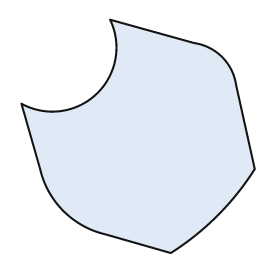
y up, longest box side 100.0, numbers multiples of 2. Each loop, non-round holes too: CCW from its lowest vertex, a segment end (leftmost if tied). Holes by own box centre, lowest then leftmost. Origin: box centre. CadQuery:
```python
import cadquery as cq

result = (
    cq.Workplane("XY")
    .moveTo(14.0, -50.0)
    .threePointArc((34.0, -34.0), (50.0, -14.0))
    .lineTo(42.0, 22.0)
    .threePointArc((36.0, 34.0), (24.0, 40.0))
    .lineTo(-12.0, 50.0)
    .threePointArc((-18.0, 18.0), (-50.0, 14.0))
    .lineTo(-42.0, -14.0)
    .threePointArc((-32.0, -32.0), (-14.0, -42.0))
    .close()
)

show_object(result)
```